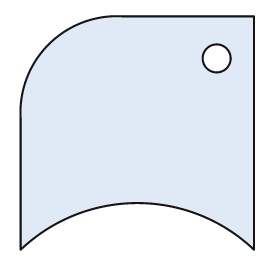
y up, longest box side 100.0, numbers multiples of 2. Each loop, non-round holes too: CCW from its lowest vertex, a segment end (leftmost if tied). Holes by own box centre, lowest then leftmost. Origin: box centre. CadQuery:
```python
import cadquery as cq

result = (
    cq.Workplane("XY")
    .moveTo(-50.0, -50.0)
    .threePointArc((0.0, -30.0), (50.0, -50.0))
    .lineTo(50.0, 50.0)
    .lineTo(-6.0, 50.0)
    .threePointArc((-38.0, 38.0), (-50.0, 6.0))
    .close()
    .moveTo(34.0, 32.0)
    .circle(6.0)
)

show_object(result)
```